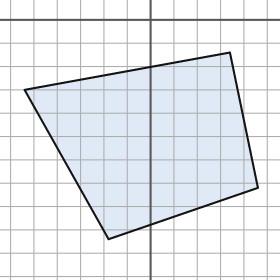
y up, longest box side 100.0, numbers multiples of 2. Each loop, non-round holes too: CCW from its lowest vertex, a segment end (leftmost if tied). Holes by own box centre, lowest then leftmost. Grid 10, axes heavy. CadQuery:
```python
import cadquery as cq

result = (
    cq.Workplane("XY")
    .moveTo(-18.0, -94.0)
    .lineTo(46.0, -72.0)
    .lineTo(34.0, -14.0)
    .lineTo(-54.0, -30.0)
    .close()
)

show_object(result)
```